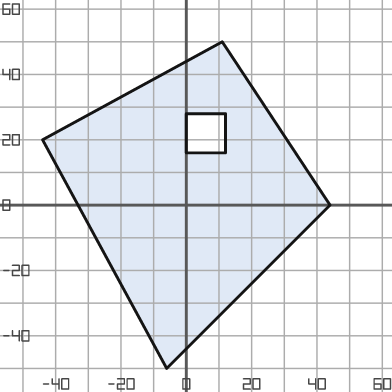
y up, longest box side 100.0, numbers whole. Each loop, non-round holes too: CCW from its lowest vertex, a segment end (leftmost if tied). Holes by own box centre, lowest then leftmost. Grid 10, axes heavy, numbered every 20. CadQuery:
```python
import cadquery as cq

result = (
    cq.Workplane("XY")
    .moveTo(-6.0, -50.0)
    .lineTo(44.0, 0.0)
    .lineTo(11.0, 50.0)
    .lineTo(-44.0, 20.0)
    .close()
    .moveTo(0.0, 16.0)
    .lineTo(12.0, 16.0)
    .lineTo(12.0, 28.0)
    .lineTo(0.0, 28.0)
    .close()
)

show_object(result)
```